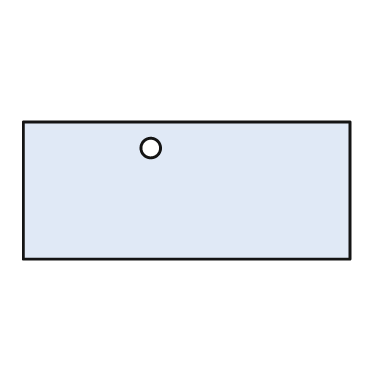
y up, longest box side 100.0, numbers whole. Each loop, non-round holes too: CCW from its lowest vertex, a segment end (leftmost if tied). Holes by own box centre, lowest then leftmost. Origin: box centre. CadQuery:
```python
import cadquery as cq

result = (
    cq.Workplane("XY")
    .moveTo(-50.0, -21.0)
    .lineTo(50.0, -21.0)
    .lineTo(50.0, 21.0)
    .lineTo(-50.0, 21.0)
    .close()
    .moveTo(-11.0, 13.0)
    .circle(3.0)
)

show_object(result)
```